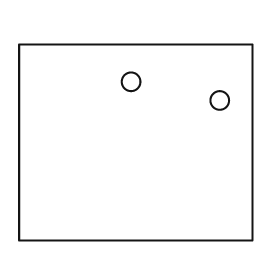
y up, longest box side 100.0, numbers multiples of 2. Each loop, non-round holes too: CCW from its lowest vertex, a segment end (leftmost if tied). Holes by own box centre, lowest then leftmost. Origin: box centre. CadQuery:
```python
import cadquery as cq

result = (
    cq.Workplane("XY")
    .moveTo(-50.0, -42.0)
    .lineTo(50.0, -42.0)
    .lineTo(50.0, 42.0)
    .lineTo(-50.0, 42.0)
    .close()
    .moveTo(36.0, 18.0)
    .circle(4.0)
    .moveTo(-2.0, 26.0)
    .circle(4.0)
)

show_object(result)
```